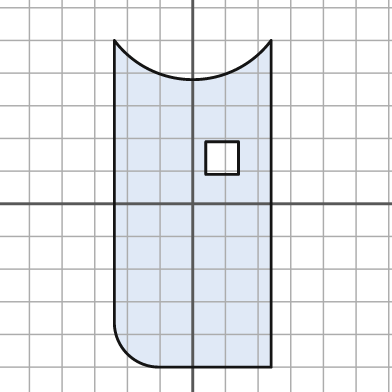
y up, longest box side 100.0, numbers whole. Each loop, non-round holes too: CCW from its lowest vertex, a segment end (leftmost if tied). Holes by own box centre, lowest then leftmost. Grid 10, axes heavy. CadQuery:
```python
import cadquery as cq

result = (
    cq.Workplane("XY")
    .moveTo(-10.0, -50.0)
    .lineTo(24.0, -50.0)
    .lineTo(24.0, 50.0)
    .threePointArc((0.0, 38.0), (-24.0, 50.0))
    .lineTo(-24.0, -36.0)
    .threePointArc((-20.0, -46.0), (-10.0, -50.0))
    .close()
    .moveTo(4.0, 9.0)
    .lineTo(14.0, 9.0)
    .lineTo(14.0, 19.0)
    .lineTo(4.0, 19.0)
    .close()
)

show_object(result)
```